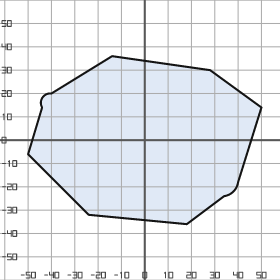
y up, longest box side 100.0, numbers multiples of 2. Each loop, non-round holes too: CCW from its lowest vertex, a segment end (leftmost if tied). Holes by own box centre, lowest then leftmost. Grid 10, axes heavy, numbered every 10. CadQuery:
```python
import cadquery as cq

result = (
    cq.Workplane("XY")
    .moveTo(18.0, -36.0)
    .lineTo(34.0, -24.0)
    .threePointArc((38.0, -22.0), (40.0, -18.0))
    .lineTo(50.0, 14.0)
    .lineTo(28.0, 30.0)
    .lineTo(-14.0, 36.0)
    .lineTo(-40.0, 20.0)
    .threePointArc((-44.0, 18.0), (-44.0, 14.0))
    .lineTo(-50.0, -6.0)
    .lineTo(-24.0, -32.0)
    .close()
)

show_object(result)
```